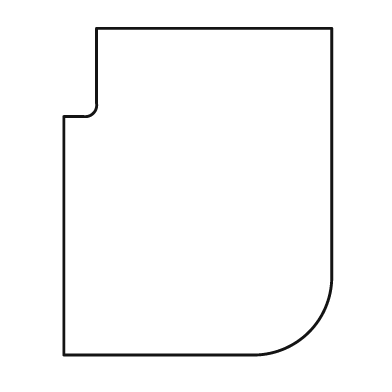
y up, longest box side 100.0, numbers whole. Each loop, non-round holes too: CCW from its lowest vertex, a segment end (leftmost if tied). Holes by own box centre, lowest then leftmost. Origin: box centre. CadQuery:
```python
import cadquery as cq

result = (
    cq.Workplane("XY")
    .moveTo(-41.0, -50.0)
    .lineTo(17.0, -50.0)
    .threePointArc((34.0, -43.0), (41.0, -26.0))
    .lineTo(41.0, 50.0)
    .lineTo(-31.0, 50.0)
    .lineTo(-31.0, 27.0)
    .threePointArc((-32.0, 24.0), (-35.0, 23.0))
    .lineTo(-41.0, 23.0)
    .close()
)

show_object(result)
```